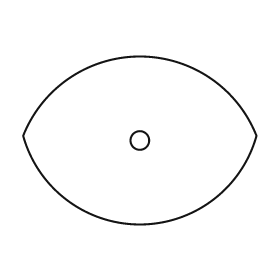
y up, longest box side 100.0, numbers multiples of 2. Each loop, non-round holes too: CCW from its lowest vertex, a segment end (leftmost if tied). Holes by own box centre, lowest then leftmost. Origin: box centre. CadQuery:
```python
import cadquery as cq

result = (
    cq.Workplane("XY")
    .moveTo(-50.0, 2.0)
    .threePointArc((0.0, -36.0), (50.0, 2.0))
    .threePointArc((0.0, 36.0), (-50.0, 2.0))
    .close()
    .moveTo(0.0, 0.0)
    .circle(4.0)
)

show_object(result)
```